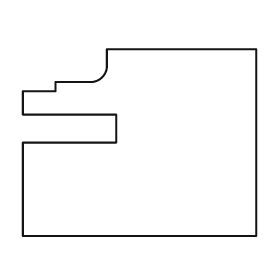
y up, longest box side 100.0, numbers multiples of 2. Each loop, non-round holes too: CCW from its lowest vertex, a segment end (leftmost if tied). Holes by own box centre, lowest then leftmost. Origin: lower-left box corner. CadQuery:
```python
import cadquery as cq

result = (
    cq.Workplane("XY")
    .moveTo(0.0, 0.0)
    .lineTo(100.0, 0.0)
    .lineTo(100.0, 80.0)
    .lineTo(36.0, 80.0)
    .lineTo(36.0, 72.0)
    .threePointArc((34.0, 68.0), (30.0, 66.0))
    .lineTo(14.0, 66.0)
    .lineTo(14.0, 62.0)
    .lineTo(0.0, 62.0)
    .lineTo(0.0, 52.0)
    .lineTo(40.0, 52.0)
    .lineTo(40.0, 40.0)
    .lineTo(0.0, 40.0)
    .close()
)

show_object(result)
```